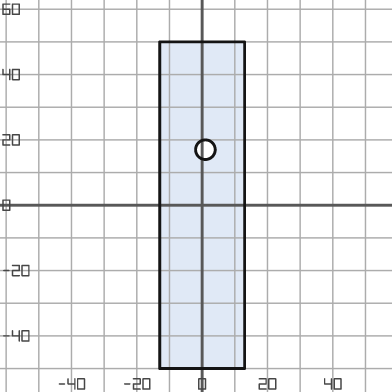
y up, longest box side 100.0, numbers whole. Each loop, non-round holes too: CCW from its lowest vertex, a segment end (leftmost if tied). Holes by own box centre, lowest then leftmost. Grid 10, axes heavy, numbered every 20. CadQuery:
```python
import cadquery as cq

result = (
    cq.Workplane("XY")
    .moveTo(-13.0, -50.0)
    .lineTo(13.0, -50.0)
    .lineTo(13.0, 50.0)
    .lineTo(-13.0, 50.0)
    .close()
    .moveTo(1.0, 17.0)
    .circle(3.0)
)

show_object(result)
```